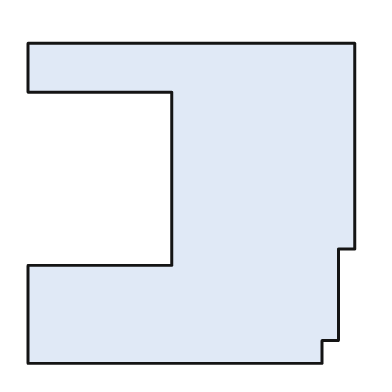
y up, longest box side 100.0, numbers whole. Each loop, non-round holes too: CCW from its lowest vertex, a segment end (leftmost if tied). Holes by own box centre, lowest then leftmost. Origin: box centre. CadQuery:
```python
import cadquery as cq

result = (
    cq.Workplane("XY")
    .moveTo(-50.0, -49.0)
    .lineTo(40.0, -49.0)
    .lineTo(40.0, -42.0)
    .lineTo(45.0, -42.0)
    .lineTo(45.0, -14.0)
    .lineTo(50.0, -14.0)
    .lineTo(50.0, 49.0)
    .lineTo(-50.0, 49.0)
    .lineTo(-50.0, 34.0)
    .lineTo(-6.0, 34.0)
    .lineTo(-6.0, -19.0)
    .lineTo(-50.0, -19.0)
    .close()
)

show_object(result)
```